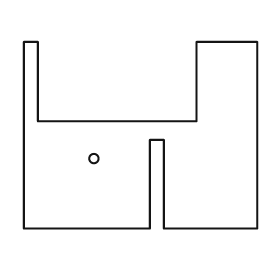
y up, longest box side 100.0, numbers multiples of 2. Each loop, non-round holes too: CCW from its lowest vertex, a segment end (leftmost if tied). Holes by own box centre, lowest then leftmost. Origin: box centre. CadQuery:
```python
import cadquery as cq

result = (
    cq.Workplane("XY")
    .moveTo(-50.0, -40.0)
    .lineTo(4.0, -40.0)
    .lineTo(4.0, -2.0)
    .lineTo(10.0, -2.0)
    .lineTo(10.0, -40.0)
    .lineTo(50.0, -40.0)
    .lineTo(50.0, 40.0)
    .lineTo(24.0, 40.0)
    .lineTo(24.0, 6.0)
    .lineTo(-44.0, 6.0)
    .lineTo(-44.0, 40.0)
    .lineTo(-50.0, 40.0)
    .close()
    .moveTo(-20.0, -10.0)
    .circle(2.0)
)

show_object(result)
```